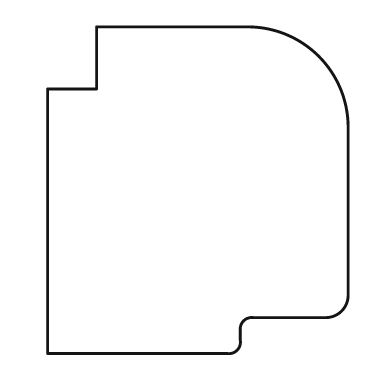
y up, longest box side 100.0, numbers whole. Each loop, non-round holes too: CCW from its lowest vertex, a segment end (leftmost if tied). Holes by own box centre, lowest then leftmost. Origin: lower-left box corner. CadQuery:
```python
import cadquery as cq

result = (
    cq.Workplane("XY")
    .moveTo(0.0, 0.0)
    .lineTo(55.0, 0.0)
    .threePointArc((58.0, 1.0), (59.0, 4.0))
    .lineTo(59.0, 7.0)
    .threePointArc((60.0, 10.0), (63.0, 11.0))
    .lineTo(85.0, 11.0)
    .threePointArc((90.0, 13.0), (92.0, 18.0))
    .lineTo(92.0, 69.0)
    .threePointArc((83.0, 91.0), (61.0, 100.0))
    .lineTo(15.0, 100.0)
    .lineTo(15.0, 81.0)
    .lineTo(0.0, 81.0)
    .close()
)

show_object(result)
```